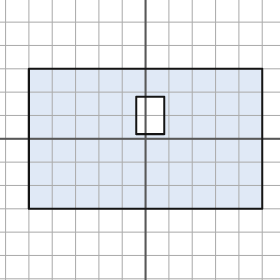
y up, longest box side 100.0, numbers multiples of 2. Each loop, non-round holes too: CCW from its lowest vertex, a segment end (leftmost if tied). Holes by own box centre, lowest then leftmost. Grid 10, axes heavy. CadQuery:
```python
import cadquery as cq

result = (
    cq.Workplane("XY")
    .moveTo(-50.0, -30.0)
    .lineTo(50.0, -30.0)
    .lineTo(50.0, 30.0)
    .lineTo(-50.0, 30.0)
    .close()
    .moveTo(-4.0, 2.0)
    .lineTo(8.0, 2.0)
    .lineTo(8.0, 18.0)
    .lineTo(-4.0, 18.0)
    .close()
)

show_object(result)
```